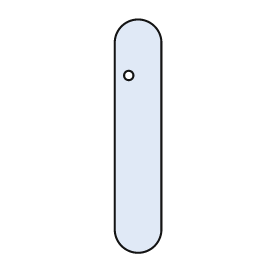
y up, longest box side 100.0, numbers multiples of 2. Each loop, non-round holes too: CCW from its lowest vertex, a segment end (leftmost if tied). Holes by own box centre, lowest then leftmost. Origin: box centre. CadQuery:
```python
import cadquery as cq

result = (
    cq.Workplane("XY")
    .moveTo(-10.0, -40.0)
    .threePointArc((0.0, -50.0), (10.0, -40.0))
    .lineTo(10.0, 40.0)
    .threePointArc((0.0, 50.0), (-10.0, 40.0))
    .close()
    .moveTo(-4.0, 26.0)
    .circle(2.0)
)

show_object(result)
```